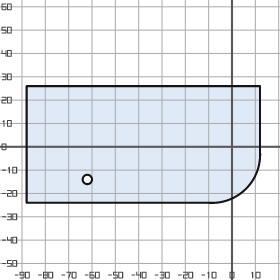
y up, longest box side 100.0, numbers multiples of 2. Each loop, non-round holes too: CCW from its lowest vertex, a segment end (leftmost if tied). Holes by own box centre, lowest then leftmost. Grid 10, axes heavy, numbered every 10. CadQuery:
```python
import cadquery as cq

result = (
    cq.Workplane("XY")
    .moveTo(-88.0, -24.0)
    .lineTo(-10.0, -24.0)
    .threePointArc((6.0, -18.0), (12.0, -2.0))
    .lineTo(12.0, 26.0)
    .lineTo(-88.0, 26.0)
    .close()
    .moveTo(-62.0, -14.0)
    .circle(2.0)
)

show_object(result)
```